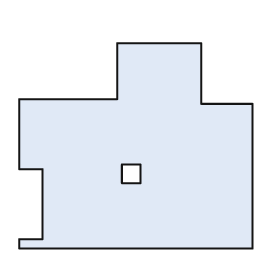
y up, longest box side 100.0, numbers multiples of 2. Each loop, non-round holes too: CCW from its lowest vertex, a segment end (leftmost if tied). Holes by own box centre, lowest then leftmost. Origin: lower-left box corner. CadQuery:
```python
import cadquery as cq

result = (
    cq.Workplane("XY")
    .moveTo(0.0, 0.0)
    .lineTo(100.0, 0.0)
    .lineTo(100.0, 62.0)
    .lineTo(78.0, 62.0)
    .lineTo(78.0, 88.0)
    .lineTo(42.0, 88.0)
    .lineTo(42.0, 64.0)
    .lineTo(0.0, 64.0)
    .lineTo(0.0, 34.0)
    .lineTo(10.0, 34.0)
    .lineTo(10.0, 4.0)
    .lineTo(0.0, 4.0)
    .close()
    .moveTo(44.0, 28.0)
    .lineTo(52.0, 28.0)
    .lineTo(52.0, 36.0)
    .lineTo(44.0, 36.0)
    .close()
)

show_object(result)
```